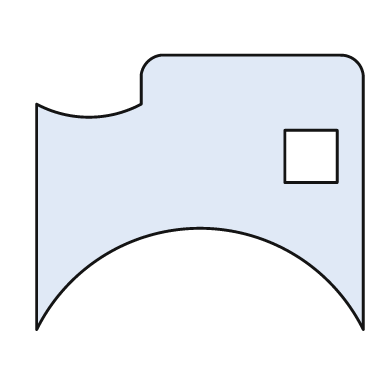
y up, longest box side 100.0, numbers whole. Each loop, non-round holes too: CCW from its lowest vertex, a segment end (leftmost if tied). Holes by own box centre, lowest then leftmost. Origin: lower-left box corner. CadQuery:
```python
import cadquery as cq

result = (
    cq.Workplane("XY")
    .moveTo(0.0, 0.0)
    .threePointArc((50.0, 31.0), (100.0, 0.0))
    .lineTo(100.0, 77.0)
    .threePointArc((98.0, 82.0), (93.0, 84.0))
    .lineTo(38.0, 84.0)
    .threePointArc((34.0, 82.0), (32.0, 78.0))
    .lineTo(32.0, 69.0)
    .threePointArc((16.0, 65.0), (0.0, 69.0))
    .close()
    .moveTo(76.0, 45.0)
    .lineTo(92.0, 45.0)
    .lineTo(92.0, 61.0)
    .lineTo(76.0, 61.0)
    .close()
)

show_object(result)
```